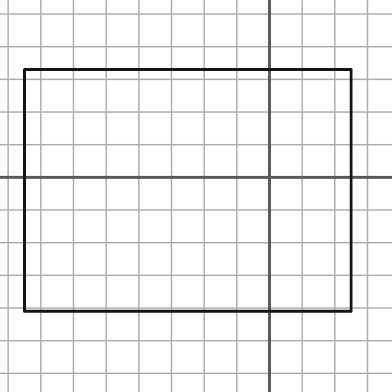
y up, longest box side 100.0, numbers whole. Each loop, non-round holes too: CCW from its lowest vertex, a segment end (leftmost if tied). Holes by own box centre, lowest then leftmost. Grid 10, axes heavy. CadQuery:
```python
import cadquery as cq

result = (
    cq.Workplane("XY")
    .moveTo(-75.0, -41.0)
    .lineTo(25.0, -41.0)
    .lineTo(25.0, 33.0)
    .lineTo(-75.0, 33.0)
    .close()
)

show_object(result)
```